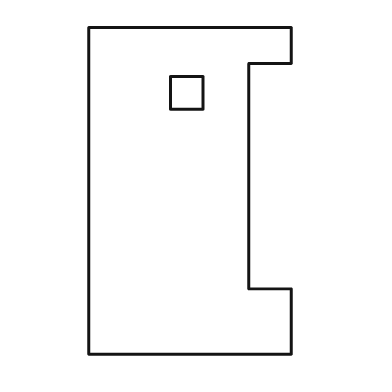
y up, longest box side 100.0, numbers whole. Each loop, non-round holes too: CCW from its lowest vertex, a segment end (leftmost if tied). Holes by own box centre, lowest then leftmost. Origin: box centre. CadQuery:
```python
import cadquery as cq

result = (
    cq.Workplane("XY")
    .moveTo(-31.0, -50.0)
    .lineTo(31.0, -50.0)
    .lineTo(31.0, -30.0)
    .lineTo(18.0, -30.0)
    .lineTo(18.0, 39.0)
    .lineTo(31.0, 39.0)
    .lineTo(31.0, 50.0)
    .lineTo(-31.0, 50.0)
    .close()
    .moveTo(-6.0, 25.0)
    .lineTo(4.0, 25.0)
    .lineTo(4.0, 35.0)
    .lineTo(-6.0, 35.0)
    .close()
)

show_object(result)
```